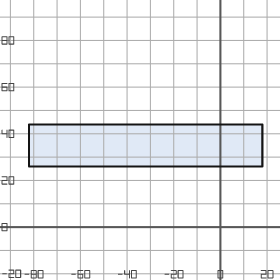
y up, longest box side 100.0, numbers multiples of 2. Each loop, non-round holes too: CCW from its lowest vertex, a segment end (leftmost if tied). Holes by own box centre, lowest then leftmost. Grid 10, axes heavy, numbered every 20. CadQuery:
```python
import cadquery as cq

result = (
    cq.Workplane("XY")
    .moveTo(-82.0, 26.0)
    .lineTo(18.0, 26.0)
    .lineTo(18.0, 44.0)
    .lineTo(-82.0, 44.0)
    .close()
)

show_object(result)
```